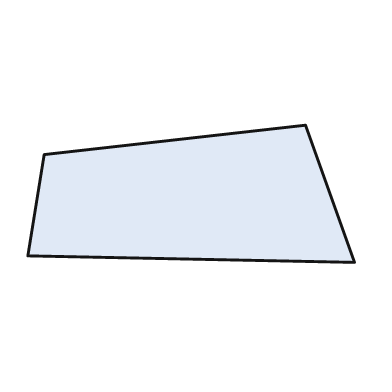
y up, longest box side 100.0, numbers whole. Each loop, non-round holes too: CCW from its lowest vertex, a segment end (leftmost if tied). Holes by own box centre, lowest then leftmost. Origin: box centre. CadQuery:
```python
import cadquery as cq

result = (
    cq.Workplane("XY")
    .moveTo(50.0, -21.0)
    .lineTo(35.0, 21.0)
    .lineTo(-45.0, 12.0)
    .lineTo(-50.0, -19.0)
    .close()
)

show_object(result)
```